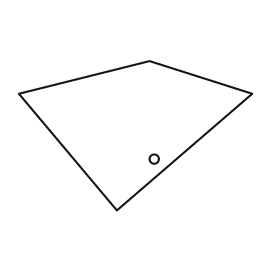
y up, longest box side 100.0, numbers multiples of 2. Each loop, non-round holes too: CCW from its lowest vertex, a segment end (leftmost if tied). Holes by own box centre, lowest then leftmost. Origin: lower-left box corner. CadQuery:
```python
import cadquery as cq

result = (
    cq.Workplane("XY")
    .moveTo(42.0, 0.0)
    .lineTo(100.0, 50.0)
    .lineTo(56.0, 64.0)
    .lineTo(0.0, 50.0)
    .close()
    .moveTo(58.0, 22.0)
    .circle(2.0)
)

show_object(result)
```